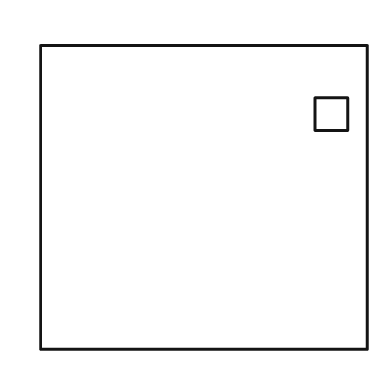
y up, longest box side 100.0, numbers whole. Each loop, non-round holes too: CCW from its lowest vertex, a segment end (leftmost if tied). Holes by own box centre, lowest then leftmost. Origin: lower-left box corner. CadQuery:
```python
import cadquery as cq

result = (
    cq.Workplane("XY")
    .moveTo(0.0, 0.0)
    .lineTo(100.0, 0.0)
    .lineTo(100.0, 93.0)
    .lineTo(0.0, 93.0)
    .close()
    .moveTo(84.0, 67.0)
    .lineTo(94.0, 67.0)
    .lineTo(94.0, 77.0)
    .lineTo(84.0, 77.0)
    .close()
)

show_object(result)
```